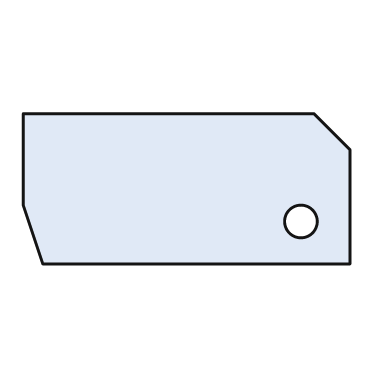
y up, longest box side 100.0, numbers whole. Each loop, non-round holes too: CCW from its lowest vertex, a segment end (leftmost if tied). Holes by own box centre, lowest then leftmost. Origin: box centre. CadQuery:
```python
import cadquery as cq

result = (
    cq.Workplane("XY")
    .moveTo(-44.0, -23.0)
    .lineTo(50.0, -23.0)
    .lineTo(50.0, 12.0)
    .lineTo(39.0, 23.0)
    .lineTo(-50.0, 23.0)
    .lineTo(-50.0, -5.0)
    .close()
    .moveTo(35.0, -10.0)
    .circle(5.0)
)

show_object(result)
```